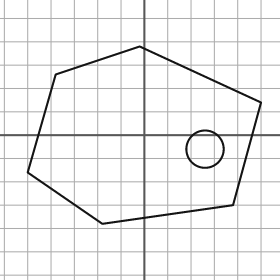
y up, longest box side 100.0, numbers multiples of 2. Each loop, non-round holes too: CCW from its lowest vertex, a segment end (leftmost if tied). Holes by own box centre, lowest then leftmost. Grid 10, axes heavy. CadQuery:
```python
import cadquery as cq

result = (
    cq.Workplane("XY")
    .moveTo(-18.0, -38.0)
    .lineTo(38.0, -30.0)
    .lineTo(50.0, 14.0)
    .lineTo(-2.0, 38.0)
    .lineTo(-38.0, 26.0)
    .lineTo(-50.0, -16.0)
    .close()
    .moveTo(26.0, -6.0)
    .circle(8.0)
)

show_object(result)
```